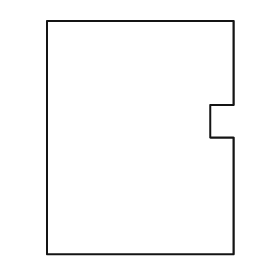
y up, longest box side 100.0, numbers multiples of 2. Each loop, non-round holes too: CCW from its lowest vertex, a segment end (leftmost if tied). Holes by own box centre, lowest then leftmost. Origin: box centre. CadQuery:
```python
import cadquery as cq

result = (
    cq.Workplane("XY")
    .moveTo(-40.0, -50.0)
    .lineTo(40.0, -50.0)
    .lineTo(40.0, 0.0)
    .lineTo(30.0, 0.0)
    .lineTo(30.0, 14.0)
    .lineTo(40.0, 14.0)
    .lineTo(40.0, 50.0)
    .lineTo(-40.0, 50.0)
    .close()
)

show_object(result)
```